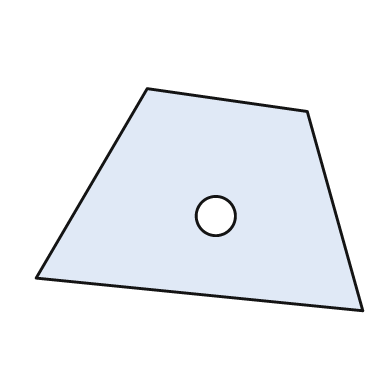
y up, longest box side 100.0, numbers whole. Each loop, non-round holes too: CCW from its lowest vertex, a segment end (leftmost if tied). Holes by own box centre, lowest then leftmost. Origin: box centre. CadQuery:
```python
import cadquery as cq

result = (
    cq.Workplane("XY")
    .moveTo(50.0, -34.0)
    .lineTo(33.0, 27.0)
    .lineTo(-16.0, 34.0)
    .lineTo(-50.0, -24.0)
    .close()
    .moveTo(5.0, -5.0)
    .circle(6.0)
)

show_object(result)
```